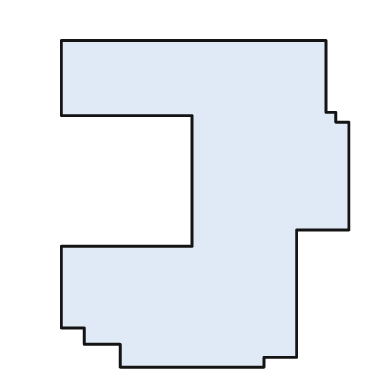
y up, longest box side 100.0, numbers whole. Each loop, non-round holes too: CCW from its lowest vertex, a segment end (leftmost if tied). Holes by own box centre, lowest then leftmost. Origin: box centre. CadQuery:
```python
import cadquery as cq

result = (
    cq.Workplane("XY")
    .moveTo(-26.0, -50.0)
    .lineTo(18.0, -50.0)
    .lineTo(18.0, -47.0)
    .lineTo(28.0, -47.0)
    .lineTo(28.0, -8.0)
    .lineTo(44.0, -8.0)
    .lineTo(44.0, 25.0)
    .lineTo(40.0, 25.0)
    .lineTo(40.0, 28.0)
    .lineTo(37.0, 28.0)
    .lineTo(37.0, 50.0)
    .lineTo(-44.0, 50.0)
    .lineTo(-44.0, 27.0)
    .lineTo(-4.0, 27.0)
    .lineTo(-4.0, -13.0)
    .lineTo(-44.0, -13.0)
    .lineTo(-44.0, -38.0)
    .lineTo(-37.0, -38.0)
    .lineTo(-37.0, -43.0)
    .lineTo(-26.0, -43.0)
    .close()
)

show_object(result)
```